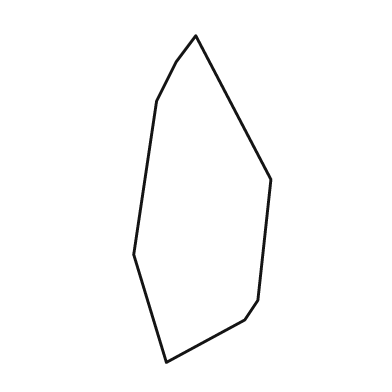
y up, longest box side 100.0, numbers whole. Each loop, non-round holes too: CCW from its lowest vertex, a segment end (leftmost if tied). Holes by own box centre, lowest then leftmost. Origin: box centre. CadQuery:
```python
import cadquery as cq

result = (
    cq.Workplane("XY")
    .moveTo(-11.0, -50.0)
    .lineTo(13.0, -37.0)
    .lineTo(17.0, -31.0)
    .lineTo(21.0, 6.0)
    .lineTo(-2.0, 50.0)
    .lineTo(-8.0, 42.0)
    .lineTo(-14.0, 30.0)
    .lineTo(-21.0, -17.0)
    .close()
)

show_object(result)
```